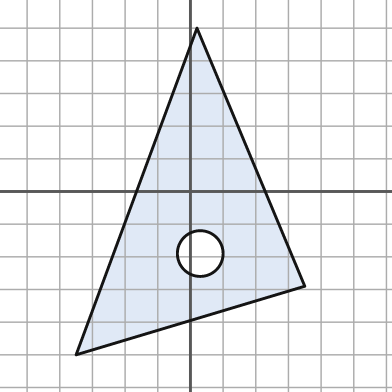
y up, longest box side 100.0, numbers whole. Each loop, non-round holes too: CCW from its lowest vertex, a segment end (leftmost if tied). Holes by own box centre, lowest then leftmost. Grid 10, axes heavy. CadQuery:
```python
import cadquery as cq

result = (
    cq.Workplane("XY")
    .moveTo(-35.0, -50.0)
    .lineTo(35.0, -29.0)
    .lineTo(2.0, 50.0)
    .close()
    .moveTo(3.0, -19.0)
    .circle(7.0)
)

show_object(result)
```